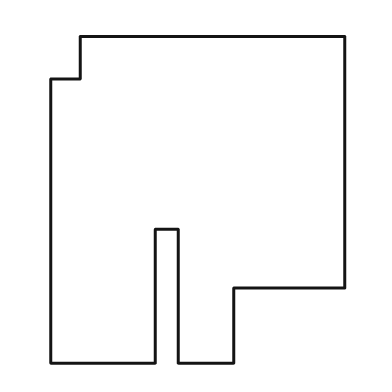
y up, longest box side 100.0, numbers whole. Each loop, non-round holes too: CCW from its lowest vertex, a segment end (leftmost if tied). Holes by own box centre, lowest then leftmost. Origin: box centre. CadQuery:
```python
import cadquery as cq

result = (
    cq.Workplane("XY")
    .moveTo(-45.0, -50.0)
    .lineTo(-13.0, -50.0)
    .lineTo(-13.0, -9.0)
    .lineTo(-6.0, -9.0)
    .lineTo(-6.0, -50.0)
    .lineTo(11.0, -50.0)
    .lineTo(11.0, -27.0)
    .lineTo(45.0, -27.0)
    .lineTo(45.0, 50.0)
    .lineTo(-36.0, 50.0)
    .lineTo(-36.0, 37.0)
    .lineTo(-45.0, 37.0)
    .close()
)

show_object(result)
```